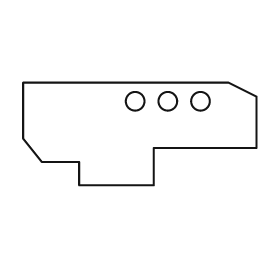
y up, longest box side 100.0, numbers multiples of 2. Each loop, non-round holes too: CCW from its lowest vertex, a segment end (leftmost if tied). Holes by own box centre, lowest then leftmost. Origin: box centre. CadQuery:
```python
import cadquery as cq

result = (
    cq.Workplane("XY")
    .moveTo(-26.0, -22.0)
    .lineTo(6.0, -22.0)
    .lineTo(6.0, -6.0)
    .lineTo(50.0, -6.0)
    .lineTo(50.0, 16.0)
    .lineTo(38.0, 22.0)
    .lineTo(-50.0, 22.0)
    .lineTo(-50.0, -2.0)
    .lineTo(-42.0, -12.0)
    .lineTo(-26.0, -12.0)
    .close()
    .moveTo(-2.0, 14.0)
    .circle(4.0)
    .moveTo(12.0, 14.0)
    .circle(4.0)
    .moveTo(26.0, 14.0)
    .circle(4.0)
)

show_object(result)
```